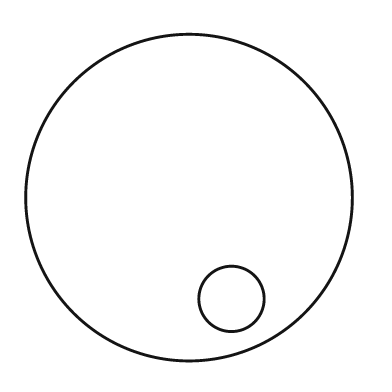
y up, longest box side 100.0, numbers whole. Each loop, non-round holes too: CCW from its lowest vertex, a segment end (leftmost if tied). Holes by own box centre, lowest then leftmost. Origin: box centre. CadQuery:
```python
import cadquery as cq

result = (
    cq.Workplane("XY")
    .moveTo(0.0, 0.0)
    .circle(50.0)
    .moveTo(13.0, -31.0)
    .circle(10.0)
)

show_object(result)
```